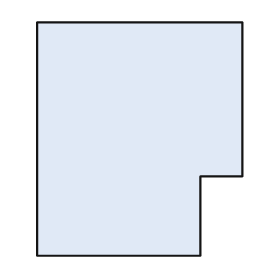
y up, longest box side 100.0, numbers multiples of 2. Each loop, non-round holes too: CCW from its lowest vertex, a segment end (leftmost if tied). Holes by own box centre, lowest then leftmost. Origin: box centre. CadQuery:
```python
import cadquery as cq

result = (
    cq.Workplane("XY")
    .moveTo(-44.0, -50.0)
    .lineTo(26.0, -50.0)
    .lineTo(26.0, -16.0)
    .lineTo(44.0, -16.0)
    .lineTo(44.0, 50.0)
    .lineTo(-44.0, 50.0)
    .close()
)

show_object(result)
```